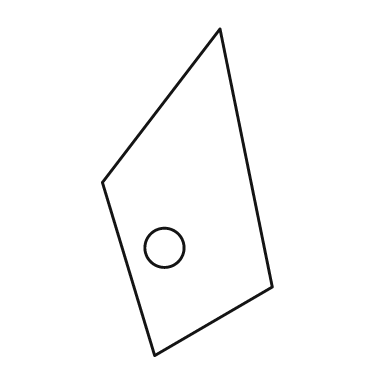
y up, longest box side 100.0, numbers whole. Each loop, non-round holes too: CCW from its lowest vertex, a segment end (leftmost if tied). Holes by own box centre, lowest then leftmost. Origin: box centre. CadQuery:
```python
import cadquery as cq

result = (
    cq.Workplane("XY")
    .moveTo(-10.0, -50.0)
    .lineTo(26.0, -29.0)
    .lineTo(10.0, 50.0)
    .lineTo(-26.0, 3.0)
    .close()
    .moveTo(-7.0, -17.0)
    .circle(6.0)
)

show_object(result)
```